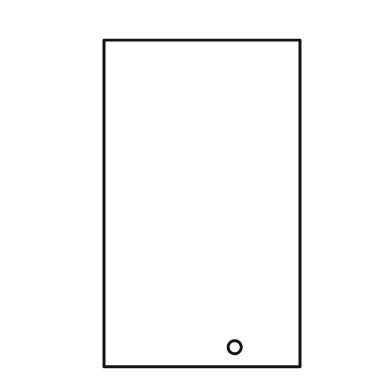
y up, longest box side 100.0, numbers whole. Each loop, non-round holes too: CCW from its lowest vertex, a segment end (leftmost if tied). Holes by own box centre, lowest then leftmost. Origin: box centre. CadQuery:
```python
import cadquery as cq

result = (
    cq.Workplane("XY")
    .moveTo(-30.0, -50.0)
    .lineTo(30.0, -50.0)
    .lineTo(30.0, 50.0)
    .lineTo(-30.0, 50.0)
    .close()
    .moveTo(10.0, -44.0)
    .circle(2.0)
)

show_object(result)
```